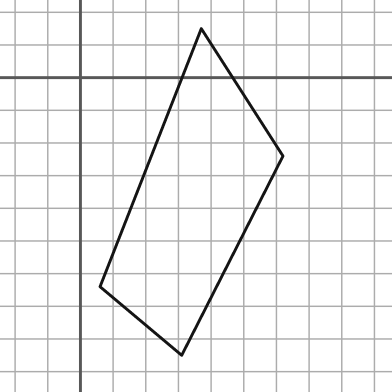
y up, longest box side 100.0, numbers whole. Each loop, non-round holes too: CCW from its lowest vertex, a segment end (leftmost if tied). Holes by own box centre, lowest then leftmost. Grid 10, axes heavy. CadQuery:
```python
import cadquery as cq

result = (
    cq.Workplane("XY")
    .moveTo(31.0, -85.0)
    .lineTo(62.0, -24.0)
    .lineTo(37.0, 15.0)
    .lineTo(6.0, -64.0)
    .close()
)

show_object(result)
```